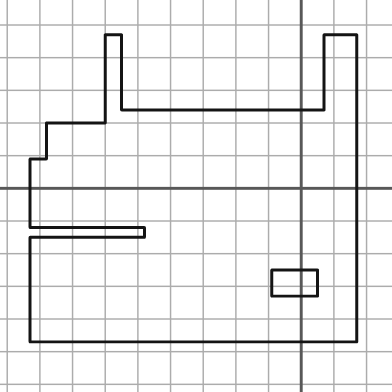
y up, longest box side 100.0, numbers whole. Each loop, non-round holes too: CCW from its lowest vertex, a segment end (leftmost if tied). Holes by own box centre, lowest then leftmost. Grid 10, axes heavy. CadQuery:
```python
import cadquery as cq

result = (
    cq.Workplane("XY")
    .moveTo(-83.0, -47.0)
    .lineTo(17.0, -47.0)
    .lineTo(17.0, 47.0)
    .lineTo(7.0, 47.0)
    .lineTo(7.0, 24.0)
    .lineTo(-55.0, 24.0)
    .lineTo(-55.0, 47.0)
    .lineTo(-60.0, 47.0)
    .lineTo(-60.0, 20.0)
    .lineTo(-78.0, 20.0)
    .lineTo(-78.0, 9.0)
    .lineTo(-83.0, 9.0)
    .lineTo(-83.0, -12.0)
    .lineTo(-48.0, -12.0)
    .lineTo(-48.0, -15.0)
    .lineTo(-83.0, -15.0)
    .close()
    .moveTo(-9.0, -33.0)
    .lineTo(5.0, -33.0)
    .lineTo(5.0, -25.0)
    .lineTo(-9.0, -25.0)
    .close()
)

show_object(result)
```